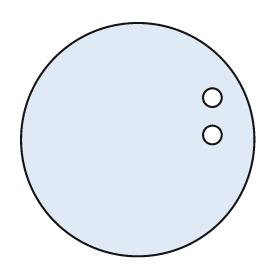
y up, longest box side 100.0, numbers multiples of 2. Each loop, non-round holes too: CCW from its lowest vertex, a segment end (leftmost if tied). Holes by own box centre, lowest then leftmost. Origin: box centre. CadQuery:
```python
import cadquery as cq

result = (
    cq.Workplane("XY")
    .moveTo(0.0, 0.0)
    .circle(50.0)
    .moveTo(32.0, 2.0)
    .circle(4.0)
    .moveTo(32.0, 18.0)
    .circle(4.0)
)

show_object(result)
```